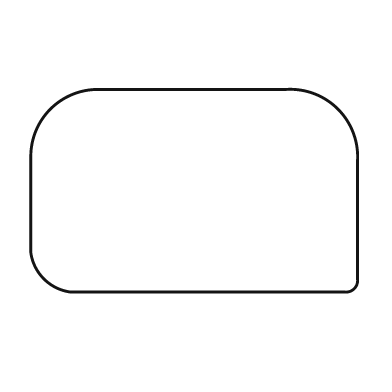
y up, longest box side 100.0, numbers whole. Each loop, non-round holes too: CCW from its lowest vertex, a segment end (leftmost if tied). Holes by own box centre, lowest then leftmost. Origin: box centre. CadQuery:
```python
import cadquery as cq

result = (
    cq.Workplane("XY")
    .moveTo(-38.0, -31.0)
    .lineTo(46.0, -31.0)
    .threePointArc((49.0, -30.0), (50.0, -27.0))
    .lineTo(50.0, 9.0)
    .threePointArc((44.0, 25.0), (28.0, 31.0))
    .lineTo(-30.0, 31.0)
    .threePointArc((-44.0, 25.0), (-50.0, 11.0))
    .lineTo(-50.0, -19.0)
    .threePointArc((-46.0, -27.0), (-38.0, -31.0))
    .close()
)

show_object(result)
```